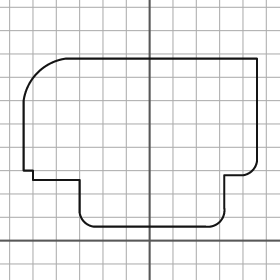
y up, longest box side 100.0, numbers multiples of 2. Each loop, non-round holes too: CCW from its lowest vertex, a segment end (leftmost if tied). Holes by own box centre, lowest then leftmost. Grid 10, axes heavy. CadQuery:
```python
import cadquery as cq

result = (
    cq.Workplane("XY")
    .moveTo(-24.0, 6.0)
    .lineTo(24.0, 6.0)
    .threePointArc((30.0, 8.0), (32.0, 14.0))
    .lineTo(32.0, 28.0)
    .lineTo(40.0, 28.0)
    .threePointArc((44.0, 30.0), (46.0, 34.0))
    .lineTo(46.0, 78.0)
    .lineTo(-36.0, 78.0)
    .threePointArc((-48.0, 72.0), (-54.0, 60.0))
    .lineTo(-54.0, 30.0)
    .lineTo(-50.0, 30.0)
    .lineTo(-50.0, 26.0)
    .lineTo(-30.0, 26.0)
    .lineTo(-30.0, 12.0)
    .threePointArc((-28.0, 8.0), (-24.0, 6.0))
    .close()
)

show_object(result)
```